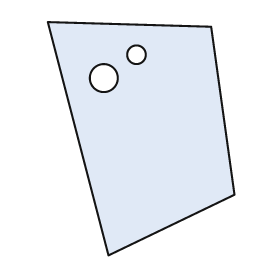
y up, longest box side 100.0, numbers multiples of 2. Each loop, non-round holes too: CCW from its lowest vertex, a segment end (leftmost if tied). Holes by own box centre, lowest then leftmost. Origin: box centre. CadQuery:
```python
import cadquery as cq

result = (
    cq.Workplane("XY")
    .moveTo(-14.0, -50.0)
    .lineTo(40.0, -24.0)
    .lineTo(30.0, 48.0)
    .lineTo(-40.0, 50.0)
    .close()
    .moveTo(-16.0, 26.0)
    .circle(6.0)
    .moveTo(-2.0, 36.0)
    .circle(4.0)
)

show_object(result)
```